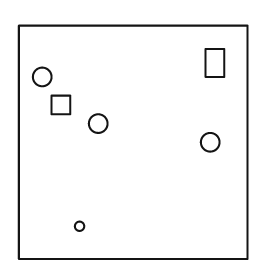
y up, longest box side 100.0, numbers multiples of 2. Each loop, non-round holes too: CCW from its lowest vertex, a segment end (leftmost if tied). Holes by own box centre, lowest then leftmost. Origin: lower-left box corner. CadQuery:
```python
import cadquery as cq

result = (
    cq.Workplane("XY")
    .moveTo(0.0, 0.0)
    .lineTo(98.0, 0.0)
    .lineTo(98.0, 100.0)
    .lineTo(0.0, 100.0)
    .close()
    .moveTo(26.0, 14.0)
    .circle(2.0)
    .moveTo(82.0, 50.0)
    .circle(4.0)
    .moveTo(34.0, 58.0)
    .circle(4.0)
    .moveTo(14.0, 62.0)
    .lineTo(22.0, 62.0)
    .lineTo(22.0, 70.0)
    .lineTo(14.0, 70.0)
    .close()
    .moveTo(10.0, 78.0)
    .circle(4.0)
    .moveTo(80.0, 78.0)
    .lineTo(88.0, 78.0)
    .lineTo(88.0, 90.0)
    .lineTo(80.0, 90.0)
    .close()
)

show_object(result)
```